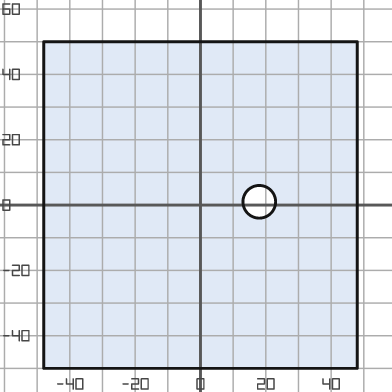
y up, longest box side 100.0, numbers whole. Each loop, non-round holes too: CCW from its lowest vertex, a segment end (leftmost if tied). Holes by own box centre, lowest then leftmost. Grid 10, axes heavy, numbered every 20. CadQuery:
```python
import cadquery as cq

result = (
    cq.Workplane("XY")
    .moveTo(-48.0, -50.0)
    .lineTo(48.0, -50.0)
    .lineTo(48.0, 50.0)
    .lineTo(-48.0, 50.0)
    .close()
    .moveTo(18.0, 1.0)
    .circle(5.0)
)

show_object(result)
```